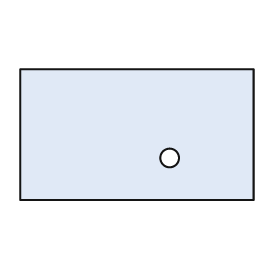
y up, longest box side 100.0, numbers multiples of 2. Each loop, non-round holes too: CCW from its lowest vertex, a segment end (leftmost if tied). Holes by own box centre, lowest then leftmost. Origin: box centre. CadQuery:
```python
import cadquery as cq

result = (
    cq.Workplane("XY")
    .moveTo(-50.0, -28.0)
    .lineTo(50.0, -28.0)
    .lineTo(50.0, 28.0)
    .lineTo(-50.0, 28.0)
    .close()
    .moveTo(14.0, -10.0)
    .circle(4.0)
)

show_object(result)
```